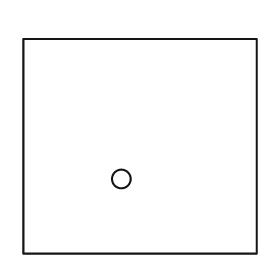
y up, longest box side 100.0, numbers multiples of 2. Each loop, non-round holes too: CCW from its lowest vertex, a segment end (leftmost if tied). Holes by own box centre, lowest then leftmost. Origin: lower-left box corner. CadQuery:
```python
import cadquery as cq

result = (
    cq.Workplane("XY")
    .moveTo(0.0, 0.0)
    .lineTo(100.0, 0.0)
    .lineTo(100.0, 92.0)
    .lineTo(0.0, 92.0)
    .close()
    .moveTo(42.0, 32.0)
    .circle(4.0)
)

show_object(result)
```